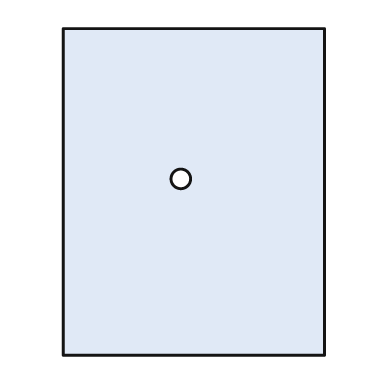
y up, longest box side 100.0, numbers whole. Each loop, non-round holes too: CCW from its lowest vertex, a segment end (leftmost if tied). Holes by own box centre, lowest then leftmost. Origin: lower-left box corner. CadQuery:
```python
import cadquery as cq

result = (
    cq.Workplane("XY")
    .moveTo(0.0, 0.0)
    .lineTo(80.0, 0.0)
    .lineTo(80.0, 100.0)
    .lineTo(0.0, 100.0)
    .close()
    .moveTo(36.0, 54.0)
    .circle(3.0)
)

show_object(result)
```